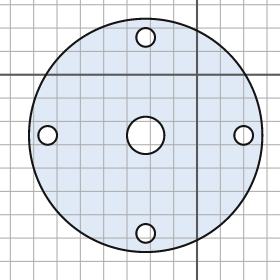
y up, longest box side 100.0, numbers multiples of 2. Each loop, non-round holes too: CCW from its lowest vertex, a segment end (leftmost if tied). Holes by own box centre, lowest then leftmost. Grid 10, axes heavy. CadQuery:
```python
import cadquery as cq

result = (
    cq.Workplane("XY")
    .moveTo(-22.0, -26.0)
    .circle(50.0)
    .moveTo(-22.0, -68.0)
    .circle(4.0)
    .moveTo(-64.0, -26.0)
    .circle(4.0)
    .moveTo(-22.0, -26.0)
    .circle(8.0)
    .moveTo(20.0, -26.0)
    .circle(4.0)
    .moveTo(-22.0, 16.0)
    .circle(4.0)
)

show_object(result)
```